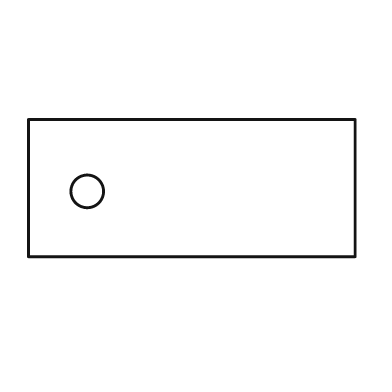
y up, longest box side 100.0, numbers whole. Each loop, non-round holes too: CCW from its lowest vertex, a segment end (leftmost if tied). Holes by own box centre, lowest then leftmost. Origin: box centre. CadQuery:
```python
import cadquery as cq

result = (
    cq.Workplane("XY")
    .moveTo(-50.0, -21.0)
    .lineTo(50.0, -21.0)
    .lineTo(50.0, 21.0)
    .lineTo(-50.0, 21.0)
    .close()
    .moveTo(-32.0, -1.0)
    .circle(5.0)
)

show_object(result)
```